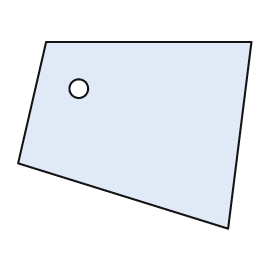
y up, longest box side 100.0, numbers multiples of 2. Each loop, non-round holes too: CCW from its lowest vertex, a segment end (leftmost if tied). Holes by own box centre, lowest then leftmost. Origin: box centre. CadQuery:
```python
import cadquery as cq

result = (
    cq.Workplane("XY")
    .moveTo(40.0, -40.0)
    .lineTo(50.0, 40.0)
    .lineTo(-38.0, 40.0)
    .lineTo(-50.0, -12.0)
    .close()
    .moveTo(-24.0, 20.0)
    .circle(4.0)
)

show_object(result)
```